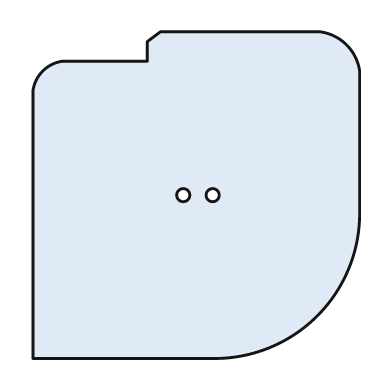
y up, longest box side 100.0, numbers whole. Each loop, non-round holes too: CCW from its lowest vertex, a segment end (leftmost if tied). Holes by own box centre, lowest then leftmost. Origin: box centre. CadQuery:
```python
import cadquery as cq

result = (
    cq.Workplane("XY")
    .moveTo(-50.0, -50.0)
    .lineTo(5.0, -50.0)
    .threePointArc((37.0, -37.0), (50.0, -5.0))
    .lineTo(50.0, 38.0)
    .threePointArc((46.0, 46.0), (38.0, 50.0))
    .lineTo(-11.0, 50.0)
    .lineTo(-15.0, 47.0)
    .lineTo(-15.0, 41.0)
    .lineTo(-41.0, 41.0)
    .threePointArc((-47.0, 38.0), (-50.0, 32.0))
    .close()
    .moveTo(-4.0, 0.0)
    .circle(2.0)
    .moveTo(5.0, 0.0)
    .circle(2.0)
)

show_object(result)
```